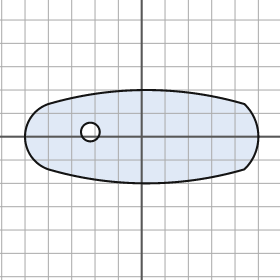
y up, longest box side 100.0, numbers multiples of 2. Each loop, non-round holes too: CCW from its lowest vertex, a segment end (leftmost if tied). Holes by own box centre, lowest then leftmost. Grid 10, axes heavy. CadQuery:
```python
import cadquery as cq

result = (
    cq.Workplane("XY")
    .moveTo(-40.0, -14.0)
    .threePointArc((2.0, -20.0), (44.0, -14.0))
    .threePointArc((50.0, 0.0), (44.0, 14.0))
    .threePointArc((2.0, 20.0), (-40.0, 14.0))
    .threePointArc((-50.0, 0.0), (-40.0, -14.0))
    .close()
    .moveTo(-22.0, 2.0)
    .circle(4.0)
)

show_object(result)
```